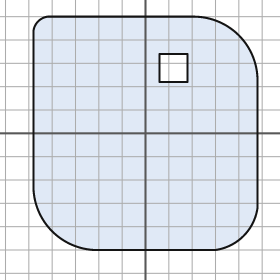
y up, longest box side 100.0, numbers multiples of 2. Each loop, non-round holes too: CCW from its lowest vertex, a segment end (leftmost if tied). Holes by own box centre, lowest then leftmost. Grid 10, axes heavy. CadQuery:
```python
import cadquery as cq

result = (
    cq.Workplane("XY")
    .moveTo(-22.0, -50.0)
    .lineTo(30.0, -50.0)
    .threePointArc((42.0, -44.0), (48.0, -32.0))
    .lineTo(48.0, 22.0)
    .threePointArc((40.0, 42.0), (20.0, 50.0))
    .lineTo(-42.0, 50.0)
    .threePointArc((-46.0, 48.0), (-48.0, 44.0))
    .lineTo(-48.0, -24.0)
    .threePointArc((-40.0, -42.0), (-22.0, -50.0))
    .close()
    .moveTo(6.0, 22.0)
    .lineTo(18.0, 22.0)
    .lineTo(18.0, 34.0)
    .lineTo(6.0, 34.0)
    .close()
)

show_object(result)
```